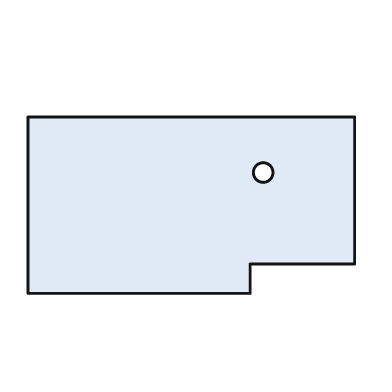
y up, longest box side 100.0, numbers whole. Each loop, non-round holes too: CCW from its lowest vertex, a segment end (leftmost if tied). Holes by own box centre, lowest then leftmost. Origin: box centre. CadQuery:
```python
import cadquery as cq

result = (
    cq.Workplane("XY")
    .moveTo(-50.0, -27.0)
    .lineTo(18.0, -27.0)
    .lineTo(18.0, -18.0)
    .lineTo(50.0, -18.0)
    .lineTo(50.0, 27.0)
    .lineTo(-50.0, 27.0)
    .close()
    .moveTo(22.0, 10.0)
    .circle(3.0)
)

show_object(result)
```